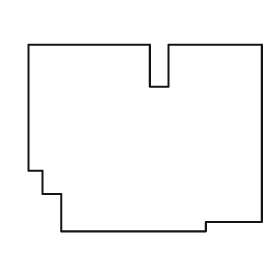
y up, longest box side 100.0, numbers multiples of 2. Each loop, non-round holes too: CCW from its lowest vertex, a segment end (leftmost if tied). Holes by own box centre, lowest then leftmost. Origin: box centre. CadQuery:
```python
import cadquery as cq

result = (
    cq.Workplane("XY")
    .moveTo(-36.0, -40.0)
    .lineTo(26.0, -40.0)
    .lineTo(26.0, -36.0)
    .lineTo(50.0, -36.0)
    .lineTo(50.0, 40.0)
    .lineTo(10.0, 40.0)
    .lineTo(10.0, 22.0)
    .lineTo(2.0, 22.0)
    .lineTo(2.0, 40.0)
    .lineTo(-50.0, 40.0)
    .lineTo(-50.0, -14.0)
    .lineTo(-44.0, -14.0)
    .lineTo(-44.0, -24.0)
    .lineTo(-36.0, -24.0)
    .close()
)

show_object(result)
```